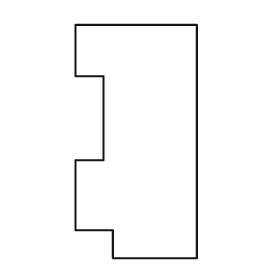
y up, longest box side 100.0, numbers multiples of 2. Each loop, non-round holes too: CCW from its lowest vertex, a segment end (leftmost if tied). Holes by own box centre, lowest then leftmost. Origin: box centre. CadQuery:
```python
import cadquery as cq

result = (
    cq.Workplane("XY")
    .moveTo(-10.0, -50.0)
    .lineTo(26.0, -50.0)
    .lineTo(26.0, 50.0)
    .lineTo(-26.0, 50.0)
    .lineTo(-26.0, 28.0)
    .lineTo(-14.0, 28.0)
    .lineTo(-14.0, -8.0)
    .lineTo(-26.0, -8.0)
    .lineTo(-26.0, -38.0)
    .lineTo(-10.0, -38.0)
    .close()
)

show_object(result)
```